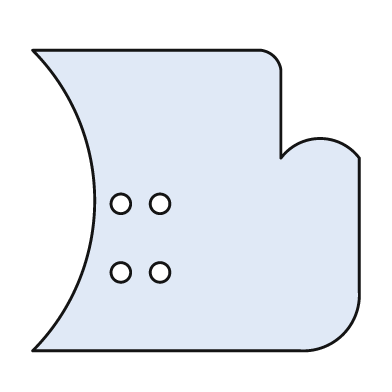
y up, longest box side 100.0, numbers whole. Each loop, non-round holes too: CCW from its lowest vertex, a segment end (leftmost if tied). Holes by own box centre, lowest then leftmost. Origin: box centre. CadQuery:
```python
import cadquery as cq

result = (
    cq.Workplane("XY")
    .moveTo(-50.0, -46.0)
    .lineTo(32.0, -46.0)
    .threePointArc((45.0, -41.0), (50.0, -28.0))
    .lineTo(50.0, 13.0)
    .threePointArc((38.0, 19.0), (26.0, 13.0))
    .lineTo(26.0, 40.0)
    .threePointArc((24.0, 44.0), (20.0, 46.0))
    .lineTo(-50.0, 46.0)
    .threePointArc((-31.0, 0.0), (-50.0, -46.0))
    .close()
    .moveTo(-23.0, -22.0)
    .circle(3.0)
    .moveTo(-11.0, -22.0)
    .circle(3.0)
    .moveTo(-23.0, -1.0)
    .circle(3.0)
    .moveTo(-11.0, -1.0)
    .circle(3.0)
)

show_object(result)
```